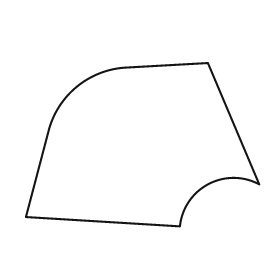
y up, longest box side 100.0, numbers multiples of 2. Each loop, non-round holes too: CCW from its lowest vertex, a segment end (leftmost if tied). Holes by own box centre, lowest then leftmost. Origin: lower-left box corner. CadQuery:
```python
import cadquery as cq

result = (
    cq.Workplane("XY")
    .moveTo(66.0, 0.0)
    .threePointArc((78.0, 18.0), (100.0, 18.0))
    .lineTo(78.0, 70.0)
    .lineTo(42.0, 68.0)
    .threePointArc((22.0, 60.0), (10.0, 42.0))
    .lineTo(0.0, 4.0)
    .close()
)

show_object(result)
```